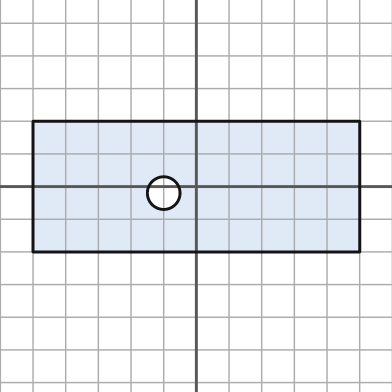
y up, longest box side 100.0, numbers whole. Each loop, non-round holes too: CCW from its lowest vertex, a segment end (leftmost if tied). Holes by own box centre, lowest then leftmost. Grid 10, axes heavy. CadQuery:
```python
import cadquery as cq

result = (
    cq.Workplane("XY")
    .moveTo(-50.0, -20.0)
    .lineTo(50.0, -20.0)
    .lineTo(50.0, 20.0)
    .lineTo(-50.0, 20.0)
    .close()
    .moveTo(-10.0, -2.0)
    .circle(5.0)
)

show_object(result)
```